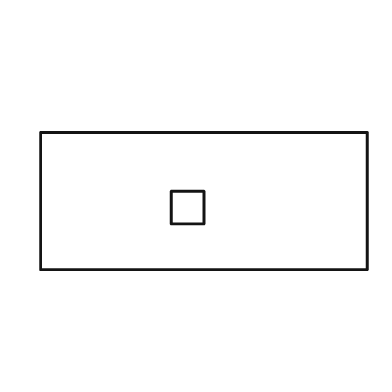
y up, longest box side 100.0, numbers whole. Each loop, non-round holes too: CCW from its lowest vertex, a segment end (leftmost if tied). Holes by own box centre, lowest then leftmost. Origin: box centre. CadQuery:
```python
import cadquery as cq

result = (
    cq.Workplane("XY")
    .moveTo(-50.0, -21.0)
    .lineTo(50.0, -21.0)
    .lineTo(50.0, 21.0)
    .lineTo(-50.0, 21.0)
    .close()
    .moveTo(-10.0, -7.0)
    .lineTo(0.0, -7.0)
    .lineTo(0.0, 3.0)
    .lineTo(-10.0, 3.0)
    .close()
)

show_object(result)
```